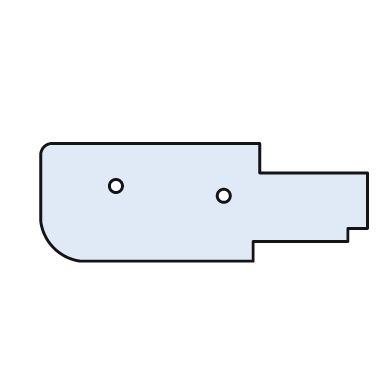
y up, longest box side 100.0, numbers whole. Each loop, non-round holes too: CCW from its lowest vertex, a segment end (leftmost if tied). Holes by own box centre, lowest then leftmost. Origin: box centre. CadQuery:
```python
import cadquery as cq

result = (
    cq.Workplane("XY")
    .moveTo(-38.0, -18.0)
    .lineTo(15.0, -18.0)
    .lineTo(15.0, -12.0)
    .lineTo(44.0, -12.0)
    .lineTo(44.0, -8.0)
    .lineTo(50.0, -8.0)
    .lineTo(50.0, 9.0)
    .lineTo(17.0, 9.0)
    .lineTo(17.0, 18.0)
    .lineTo(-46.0, 18.0)
    .threePointArc((-49.0, 17.0), (-50.0, 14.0))
    .lineTo(-50.0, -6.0)
    .threePointArc((-46.0, -14.0), (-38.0, -18.0))
    .close()
    .moveTo(6.0, 2.0)
    .circle(2.0)
    .moveTo(-27.0, 5.0)
    .circle(2.0)
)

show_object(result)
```